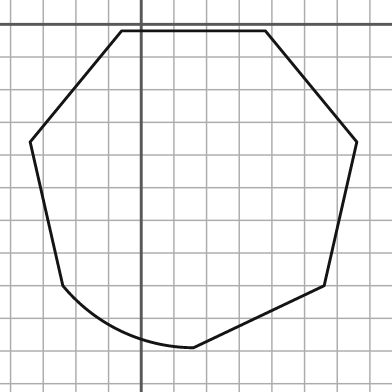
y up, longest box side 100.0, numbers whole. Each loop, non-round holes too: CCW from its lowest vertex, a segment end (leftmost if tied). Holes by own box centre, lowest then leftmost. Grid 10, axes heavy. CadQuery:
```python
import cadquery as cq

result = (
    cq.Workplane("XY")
    .moveTo(16.0, -99.0)
    .lineTo(56.0, -80.0)
    .lineTo(66.0, -36.0)
    .lineTo(38.0, -2.0)
    .lineTo(-6.0, -2.0)
    .lineTo(-34.0, -36.0)
    .lineTo(-24.0, -80.0)
    .threePointArc((-6.0, -94.0), (16.0, -99.0))
    .close()
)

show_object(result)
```